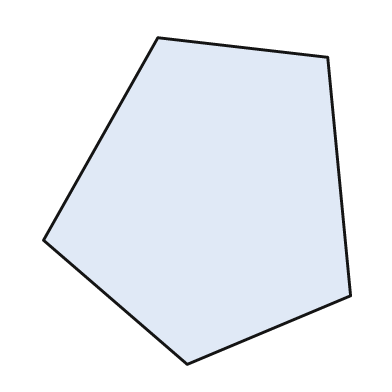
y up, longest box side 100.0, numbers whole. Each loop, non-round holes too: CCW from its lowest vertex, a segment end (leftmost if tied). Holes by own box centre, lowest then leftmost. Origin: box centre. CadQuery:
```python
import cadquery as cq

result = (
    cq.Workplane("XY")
    .moveTo(-3.0, -50.0)
    .lineTo(47.0, -29.0)
    .lineTo(40.0, 44.0)
    .lineTo(-12.0, 50.0)
    .lineTo(-47.0, -12.0)
    .close()
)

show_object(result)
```